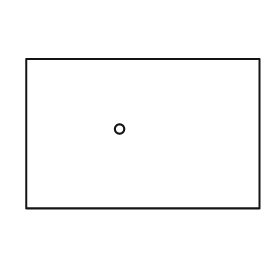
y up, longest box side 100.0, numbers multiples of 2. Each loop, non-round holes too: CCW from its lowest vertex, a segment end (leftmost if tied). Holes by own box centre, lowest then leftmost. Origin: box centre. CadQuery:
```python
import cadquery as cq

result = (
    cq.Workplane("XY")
    .moveTo(-50.0, -32.0)
    .lineTo(50.0, -32.0)
    .lineTo(50.0, 32.0)
    .lineTo(-50.0, 32.0)
    .close()
    .moveTo(-10.0, 2.0)
    .circle(2.0)
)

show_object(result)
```